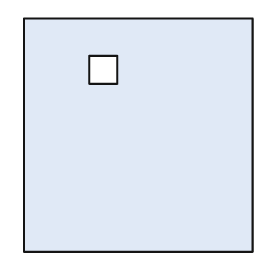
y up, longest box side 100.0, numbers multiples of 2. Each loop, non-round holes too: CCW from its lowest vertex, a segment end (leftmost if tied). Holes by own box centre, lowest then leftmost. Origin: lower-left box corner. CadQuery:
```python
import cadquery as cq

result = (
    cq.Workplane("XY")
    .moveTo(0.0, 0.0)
    .lineTo(98.0, 0.0)
    .lineTo(98.0, 100.0)
    .lineTo(0.0, 100.0)
    .close()
    .moveTo(28.0, 72.0)
    .lineTo(40.0, 72.0)
    .lineTo(40.0, 84.0)
    .lineTo(28.0, 84.0)
    .close()
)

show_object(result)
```